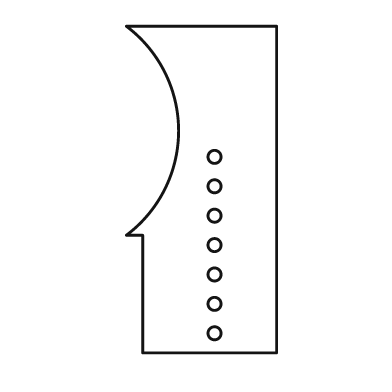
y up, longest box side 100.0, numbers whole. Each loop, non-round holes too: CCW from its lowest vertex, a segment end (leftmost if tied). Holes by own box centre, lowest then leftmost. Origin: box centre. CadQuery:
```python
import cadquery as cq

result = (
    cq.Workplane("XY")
    .moveTo(-18.0, -50.0)
    .lineTo(23.0, -50.0)
    .lineTo(23.0, 50.0)
    .lineTo(-23.0, 50.0)
    .threePointArc((-7.0, 18.0), (-23.0, -14.0))
    .lineTo(-18.0, -14.0)
    .close()
    .moveTo(4.0, -44.0)
    .circle(2.0)
    .moveTo(4.0, -35.0)
    .circle(2.0)
    .moveTo(4.0, -26.0)
    .circle(2.0)
    .moveTo(4.0, -17.0)
    .circle(2.0)
    .moveTo(4.0, -8.0)
    .circle(2.0)
    .moveTo(4.0, 1.0)
    .circle(2.0)
    .moveTo(4.0, 10.0)
    .circle(2.0)
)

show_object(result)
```